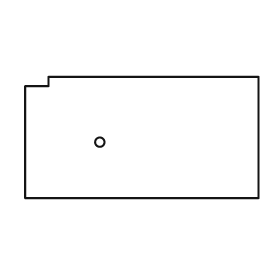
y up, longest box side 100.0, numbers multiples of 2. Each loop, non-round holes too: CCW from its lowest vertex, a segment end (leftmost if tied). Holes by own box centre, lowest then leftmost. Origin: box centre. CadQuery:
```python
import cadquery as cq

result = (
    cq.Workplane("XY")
    .moveTo(-50.0, -26.0)
    .lineTo(50.0, -26.0)
    .lineTo(50.0, 26.0)
    .lineTo(-40.0, 26.0)
    .lineTo(-40.0, 22.0)
    .lineTo(-50.0, 22.0)
    .close()
    .moveTo(-18.0, -2.0)
    .circle(2.0)
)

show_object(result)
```